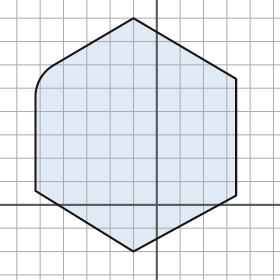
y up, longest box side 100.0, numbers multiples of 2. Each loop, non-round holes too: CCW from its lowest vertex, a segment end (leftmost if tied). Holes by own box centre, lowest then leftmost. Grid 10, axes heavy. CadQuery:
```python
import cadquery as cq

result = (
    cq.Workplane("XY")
    .moveTo(-10.0, -20.0)
    .lineTo(34.0, 4.0)
    .lineTo(34.0, 54.0)
    .lineTo(-10.0, 80.0)
    .lineTo(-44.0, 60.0)
    .threePointArc((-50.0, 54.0), (-52.0, 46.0))
    .lineTo(-52.0, 6.0)
    .close()
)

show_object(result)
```